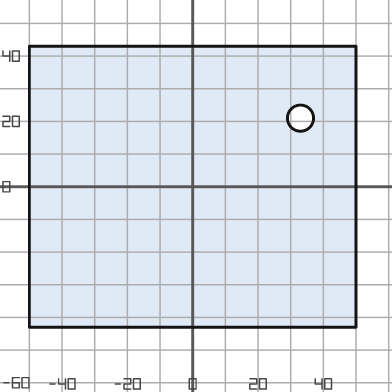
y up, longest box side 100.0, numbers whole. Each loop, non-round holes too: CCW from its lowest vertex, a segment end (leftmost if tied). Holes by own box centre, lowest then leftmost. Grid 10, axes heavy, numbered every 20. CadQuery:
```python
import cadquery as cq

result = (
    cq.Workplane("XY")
    .moveTo(-50.0, -43.0)
    .lineTo(50.0, -43.0)
    .lineTo(50.0, 43.0)
    .lineTo(-50.0, 43.0)
    .close()
    .moveTo(33.0, 21.0)
    .circle(4.0)
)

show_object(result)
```